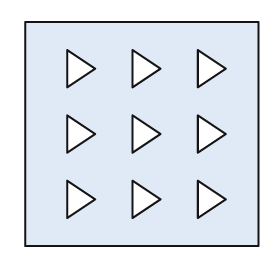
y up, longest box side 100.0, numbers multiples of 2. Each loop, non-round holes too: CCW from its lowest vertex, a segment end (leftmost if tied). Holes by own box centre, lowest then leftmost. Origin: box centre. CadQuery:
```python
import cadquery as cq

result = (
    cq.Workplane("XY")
    .moveTo(-50.0, -48.0)
    .lineTo(50.0, -48.0)
    .lineTo(50.0, 48.0)
    .lineTo(-50.0, 48.0)
    .close()
    .moveTo(-32.0, -36.0)
    .lineTo(-20.0, -28.0)
    .lineTo(-32.0, -20.0)
    .close()
    .moveTo(-4.0, -36.0)
    .lineTo(8.0, -28.0)
    .lineTo(-4.0, -20.0)
    .close()
    .moveTo(24.0, -36.0)
    .lineTo(36.0, -28.0)
    .lineTo(24.0, -20.0)
    .close()
    .moveTo(-32.0, -8.0)
    .lineTo(-20.0, 0.0)
    .lineTo(-32.0, 8.0)
    .close()
    .moveTo(-4.0, -8.0)
    .lineTo(8.0, 0.0)
    .lineTo(-4.0, 8.0)
    .close()
    .moveTo(24.0, -8.0)
    .lineTo(36.0, 0.0)
    .lineTo(24.0, 8.0)
    .close()
    .moveTo(-32.0, 20.0)
    .lineTo(-20.0, 28.0)
    .lineTo(-32.0, 36.0)
    .close()
    .moveTo(-4.0, 20.0)
    .lineTo(8.0, 28.0)
    .lineTo(-4.0, 36.0)
    .close()
    .moveTo(24.0, 20.0)
    .lineTo(36.0, 28.0)
    .lineTo(24.0, 36.0)
    .close()
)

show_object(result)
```